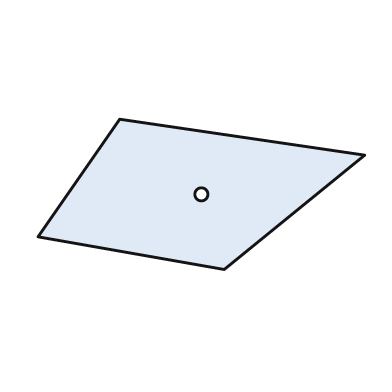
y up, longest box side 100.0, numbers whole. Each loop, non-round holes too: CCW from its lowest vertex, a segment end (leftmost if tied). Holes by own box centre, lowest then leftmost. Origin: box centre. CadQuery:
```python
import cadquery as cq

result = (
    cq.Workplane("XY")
    .moveTo(7.0, -23.0)
    .lineTo(50.0, 12.0)
    .lineTo(-25.0, 23.0)
    .lineTo(-50.0, -13.0)
    .close()
    .moveTo(0.0, 0.0)
    .circle(2.0)
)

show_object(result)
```